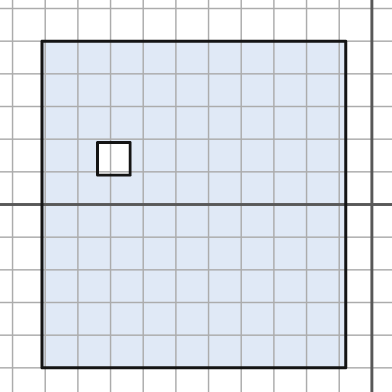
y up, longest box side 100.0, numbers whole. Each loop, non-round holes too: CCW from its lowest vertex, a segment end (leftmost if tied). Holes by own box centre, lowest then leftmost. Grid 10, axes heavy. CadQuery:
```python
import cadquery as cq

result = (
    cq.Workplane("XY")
    .moveTo(-101.0, -50.0)
    .lineTo(-8.0, -50.0)
    .lineTo(-8.0, 50.0)
    .lineTo(-101.0, 50.0)
    .close()
    .moveTo(-84.0, 9.0)
    .lineTo(-74.0, 9.0)
    .lineTo(-74.0, 19.0)
    .lineTo(-84.0, 19.0)
    .close()
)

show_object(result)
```